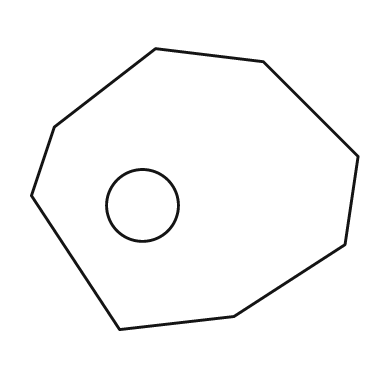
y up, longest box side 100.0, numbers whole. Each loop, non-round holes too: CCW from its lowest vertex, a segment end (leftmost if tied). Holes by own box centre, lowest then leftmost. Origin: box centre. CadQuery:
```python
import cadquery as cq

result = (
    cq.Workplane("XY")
    .moveTo(-23.0, -43.0)
    .lineTo(12.0, -39.0)
    .lineTo(46.0, -17.0)
    .lineTo(50.0, 10.0)
    .lineTo(21.0, 39.0)
    .lineTo(-12.0, 43.0)
    .lineTo(-43.0, 19.0)
    .lineTo(-50.0, -2.0)
    .close()
    .moveTo(-16.0, -5.0)
    .circle(11.0)
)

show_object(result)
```